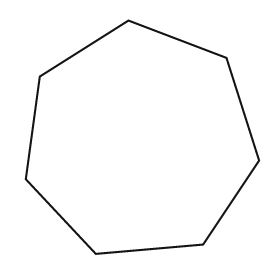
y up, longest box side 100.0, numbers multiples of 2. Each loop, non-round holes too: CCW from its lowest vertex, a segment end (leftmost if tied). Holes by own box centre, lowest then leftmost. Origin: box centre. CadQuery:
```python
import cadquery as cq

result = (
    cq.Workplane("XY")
    .moveTo(-20.0, -50.0)
    .lineTo(26.0, -46.0)
    .lineTo(50.0, -10.0)
    .lineTo(36.0, 34.0)
    .lineTo(-6.0, 50.0)
    .lineTo(-44.0, 26.0)
    .lineTo(-50.0, -18.0)
    .close()
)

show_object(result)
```